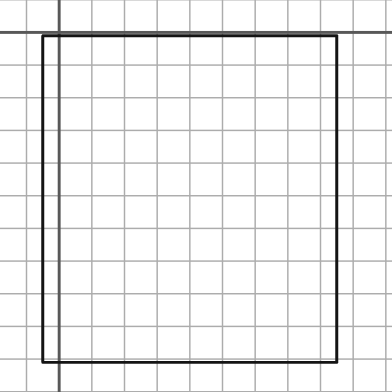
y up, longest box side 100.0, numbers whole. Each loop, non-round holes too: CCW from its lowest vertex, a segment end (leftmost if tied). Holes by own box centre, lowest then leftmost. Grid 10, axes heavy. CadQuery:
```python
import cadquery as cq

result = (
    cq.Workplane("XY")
    .moveTo(-5.0, -101.0)
    .lineTo(85.0, -101.0)
    .lineTo(85.0, -1.0)
    .lineTo(-5.0, -1.0)
    .close()
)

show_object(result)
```